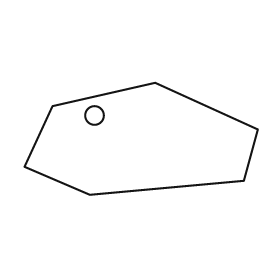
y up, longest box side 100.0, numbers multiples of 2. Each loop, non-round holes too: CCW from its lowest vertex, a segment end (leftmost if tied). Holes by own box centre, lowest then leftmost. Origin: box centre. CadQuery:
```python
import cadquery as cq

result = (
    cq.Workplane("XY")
    .moveTo(-22.0, -24.0)
    .lineTo(44.0, -18.0)
    .lineTo(50.0, 4.0)
    .lineTo(6.0, 24.0)
    .lineTo(-38.0, 14.0)
    .lineTo(-50.0, -12.0)
    .close()
    .moveTo(-20.0, 10.0)
    .circle(4.0)
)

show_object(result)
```